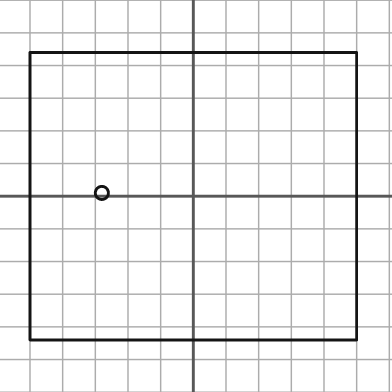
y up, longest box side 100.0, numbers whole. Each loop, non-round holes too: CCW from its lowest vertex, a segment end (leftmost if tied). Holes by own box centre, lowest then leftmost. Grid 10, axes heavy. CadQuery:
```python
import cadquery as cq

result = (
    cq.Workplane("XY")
    .moveTo(-50.0, -44.0)
    .lineTo(50.0, -44.0)
    .lineTo(50.0, 44.0)
    .lineTo(-50.0, 44.0)
    .close()
    .moveTo(-28.0, 1.0)
    .circle(2.0)
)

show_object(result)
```